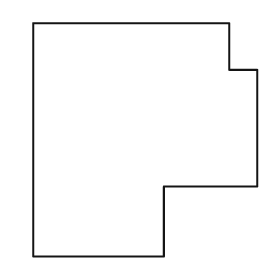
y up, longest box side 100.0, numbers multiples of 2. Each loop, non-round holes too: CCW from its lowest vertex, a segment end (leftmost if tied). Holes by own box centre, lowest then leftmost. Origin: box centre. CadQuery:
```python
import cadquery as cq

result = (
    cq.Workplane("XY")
    .moveTo(-48.0, -50.0)
    .lineTo(8.0, -50.0)
    .lineTo(8.0, -20.0)
    .lineTo(48.0, -20.0)
    .lineTo(48.0, 30.0)
    .lineTo(36.0, 30.0)
    .lineTo(36.0, 50.0)
    .lineTo(-48.0, 50.0)
    .close()
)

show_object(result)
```